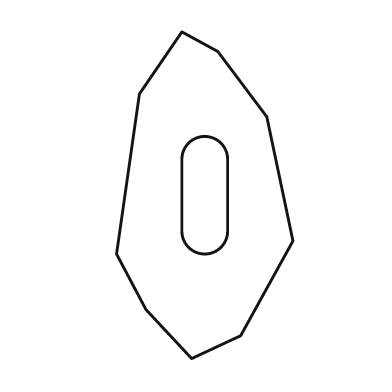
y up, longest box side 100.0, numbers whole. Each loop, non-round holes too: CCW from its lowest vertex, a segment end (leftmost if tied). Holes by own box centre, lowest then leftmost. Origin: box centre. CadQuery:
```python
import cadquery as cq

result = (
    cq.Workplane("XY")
    .moveTo(-4.0, -50.0)
    .lineTo(11.0, -43.0)
    .lineTo(27.0, -14.0)
    .lineTo(19.0, 24.0)
    .lineTo(4.0, 44.0)
    .lineTo(-7.0, 50.0)
    .lineTo(-20.0, 31.0)
    .lineTo(-27.0, -18.0)
    .lineTo(-18.0, -35.0)
    .close()
    .moveTo(-7.0, -11.0)
    .threePointArc((0.0, -18.0), (7.0, -11.0))
    .lineTo(7.0, 11.0)
    .threePointArc((0.0, 18.0), (-7.0, 11.0))
    .close()
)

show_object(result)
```